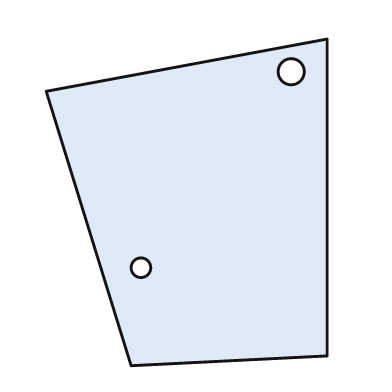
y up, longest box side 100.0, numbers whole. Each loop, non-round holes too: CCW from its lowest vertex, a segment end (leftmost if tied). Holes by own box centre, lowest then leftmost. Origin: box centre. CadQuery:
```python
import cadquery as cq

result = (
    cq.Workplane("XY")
    .moveTo(-17.0, -50.0)
    .lineTo(43.0, -47.0)
    .lineTo(43.0, 50.0)
    .lineTo(-43.0, 34.0)
    .close()
    .moveTo(-14.0, -20.0)
    .circle(3.0)
    .moveTo(32.0, 40.0)
    .circle(4.0)
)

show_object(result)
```